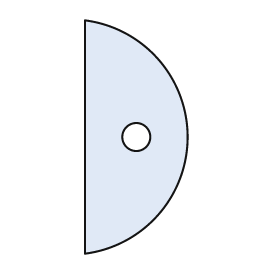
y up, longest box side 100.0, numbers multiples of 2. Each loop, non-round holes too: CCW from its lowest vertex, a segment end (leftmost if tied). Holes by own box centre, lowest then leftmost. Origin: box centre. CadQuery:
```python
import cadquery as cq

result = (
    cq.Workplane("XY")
    .moveTo(-22.0, -50.0)
    .threePointArc((22.0, 0.0), (-22.0, 50.0))
    .close()
    .moveTo(0.0, 0.0)
    .circle(6.0)
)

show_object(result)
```